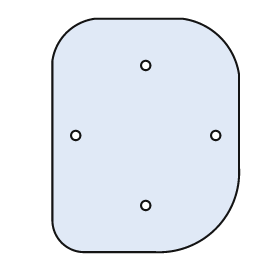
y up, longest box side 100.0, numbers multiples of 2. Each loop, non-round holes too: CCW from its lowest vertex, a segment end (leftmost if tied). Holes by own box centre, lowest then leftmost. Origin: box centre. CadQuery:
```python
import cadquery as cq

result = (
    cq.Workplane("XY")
    .moveTo(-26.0, -50.0)
    .lineTo(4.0, -50.0)
    .threePointArc((30.0, -40.0), (40.0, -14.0))
    .lineTo(40.0, 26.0)
    .threePointArc((32.0, 42.0), (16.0, 50.0))
    .lineTo(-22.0, 50.0)
    .threePointArc((-34.0, 44.0), (-40.0, 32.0))
    .lineTo(-40.0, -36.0)
    .threePointArc((-36.0, -46.0), (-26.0, -50.0))
    .close()
    .moveTo(0.0, -30.0)
    .circle(2.0)
    .moveTo(-30.0, 0.0)
    .circle(2.0)
    .moveTo(30.0, 0.0)
    .circle(2.0)
    .moveTo(0.0, 30.0)
    .circle(2.0)
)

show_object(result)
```